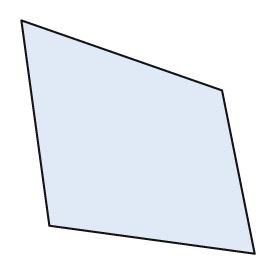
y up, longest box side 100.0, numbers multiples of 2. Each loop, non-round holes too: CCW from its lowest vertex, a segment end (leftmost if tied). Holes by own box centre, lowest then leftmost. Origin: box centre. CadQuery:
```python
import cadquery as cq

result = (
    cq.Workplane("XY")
    .moveTo(50.0, -50.0)
    .lineTo(36.0, 20.0)
    .lineTo(-50.0, 50.0)
    .lineTo(-38.0, -38.0)
    .close()
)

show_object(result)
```